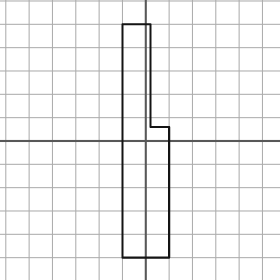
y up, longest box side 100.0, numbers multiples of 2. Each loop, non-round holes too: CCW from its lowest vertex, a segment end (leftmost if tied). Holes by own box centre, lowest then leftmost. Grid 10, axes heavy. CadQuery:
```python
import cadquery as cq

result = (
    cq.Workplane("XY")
    .moveTo(-10.0, -50.0)
    .lineTo(10.0, -50.0)
    .lineTo(10.0, 6.0)
    .lineTo(2.0, 6.0)
    .lineTo(2.0, 50.0)
    .lineTo(-10.0, 50.0)
    .close()
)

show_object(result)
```